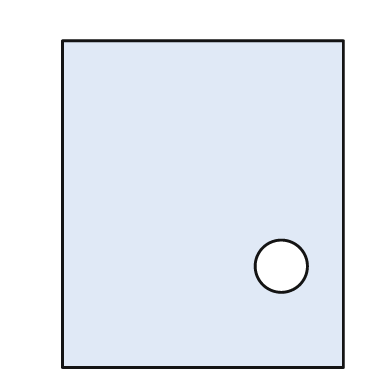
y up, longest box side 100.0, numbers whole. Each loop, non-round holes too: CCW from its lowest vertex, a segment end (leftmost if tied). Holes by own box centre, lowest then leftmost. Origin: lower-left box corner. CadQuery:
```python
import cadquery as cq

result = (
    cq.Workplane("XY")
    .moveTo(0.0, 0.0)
    .lineTo(86.0, 0.0)
    .lineTo(86.0, 100.0)
    .lineTo(0.0, 100.0)
    .close()
    .moveTo(67.0, 31.0)
    .circle(8.0)
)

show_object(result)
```